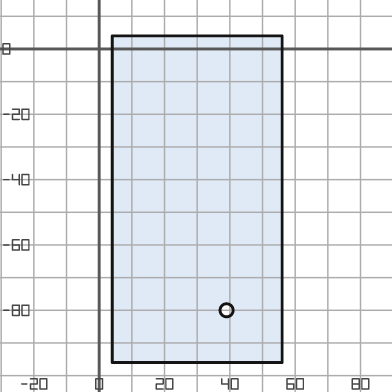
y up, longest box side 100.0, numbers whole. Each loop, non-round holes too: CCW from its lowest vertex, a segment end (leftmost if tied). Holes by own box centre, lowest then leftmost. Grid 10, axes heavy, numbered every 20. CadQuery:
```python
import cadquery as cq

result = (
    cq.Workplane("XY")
    .moveTo(4.0, -96.0)
    .lineTo(56.0, -96.0)
    .lineTo(56.0, 4.0)
    .lineTo(4.0, 4.0)
    .close()
    .moveTo(39.0, -80.0)
    .circle(2.0)
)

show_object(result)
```